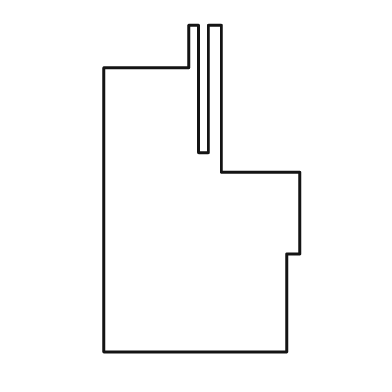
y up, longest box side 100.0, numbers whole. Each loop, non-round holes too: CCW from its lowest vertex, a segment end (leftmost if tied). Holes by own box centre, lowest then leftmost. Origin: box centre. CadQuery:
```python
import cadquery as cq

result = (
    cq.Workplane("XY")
    .moveTo(-30.0, -50.0)
    .lineTo(26.0, -50.0)
    .lineTo(26.0, -20.0)
    .lineTo(30.0, -20.0)
    .lineTo(30.0, 5.0)
    .lineTo(6.0, 5.0)
    .lineTo(6.0, 50.0)
    .lineTo(2.0, 50.0)
    .lineTo(2.0, 11.0)
    .lineTo(-1.0, 11.0)
    .lineTo(-1.0, 50.0)
    .lineTo(-4.0, 50.0)
    .lineTo(-4.0, 37.0)
    .lineTo(-30.0, 37.0)
    .close()
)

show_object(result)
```